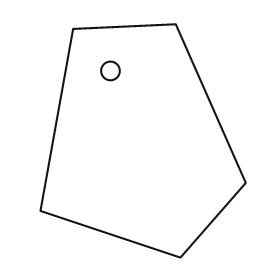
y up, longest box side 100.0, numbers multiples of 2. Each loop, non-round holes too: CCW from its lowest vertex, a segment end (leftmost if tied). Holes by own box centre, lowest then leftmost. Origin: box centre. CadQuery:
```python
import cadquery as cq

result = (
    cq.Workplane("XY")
    .moveTo(16.0, -50.0)
    .lineTo(44.0, -18.0)
    .lineTo(14.0, 50.0)
    .lineTo(-30.0, 48.0)
    .lineTo(-44.0, -30.0)
    .close()
    .moveTo(-14.0, 30.0)
    .circle(4.0)
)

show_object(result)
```